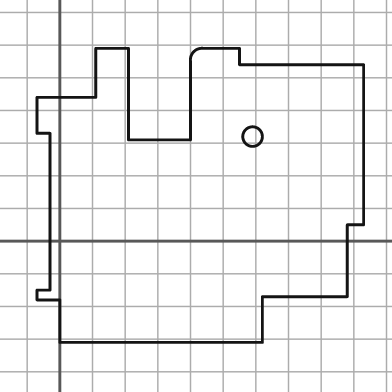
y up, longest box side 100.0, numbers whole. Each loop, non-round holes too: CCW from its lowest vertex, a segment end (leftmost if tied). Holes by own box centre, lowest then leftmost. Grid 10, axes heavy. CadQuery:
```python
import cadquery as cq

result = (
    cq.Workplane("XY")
    .moveTo(0.0, -31.0)
    .lineTo(62.0, -31.0)
    .lineTo(62.0, -17.0)
    .lineTo(88.0, -17.0)
    .lineTo(88.0, 5.0)
    .lineTo(93.0, 5.0)
    .lineTo(93.0, 54.0)
    .lineTo(55.0, 54.0)
    .lineTo(55.0, 59.0)
    .lineTo(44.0, 59.0)
    .threePointArc((41.0, 58.0), (40.0, 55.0))
    .lineTo(40.0, 31.0)
    .lineTo(21.0, 31.0)
    .lineTo(21.0, 59.0)
    .lineTo(11.0, 59.0)
    .lineTo(11.0, 44.0)
    .lineTo(-7.0, 44.0)
    .lineTo(-7.0, 33.0)
    .lineTo(-3.0, 33.0)
    .lineTo(-3.0, -15.0)
    .lineTo(-7.0, -15.0)
    .lineTo(-7.0, -18.0)
    .lineTo(0.0, -18.0)
    .close()
    .moveTo(59.0, 32.0)
    .circle(3.0)
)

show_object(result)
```